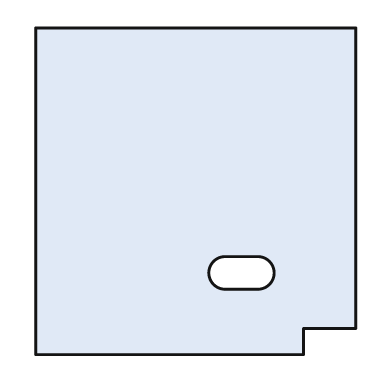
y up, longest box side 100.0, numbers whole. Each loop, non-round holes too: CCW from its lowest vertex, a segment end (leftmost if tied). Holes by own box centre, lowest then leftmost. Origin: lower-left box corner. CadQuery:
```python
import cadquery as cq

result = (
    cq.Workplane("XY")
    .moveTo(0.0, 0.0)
    .lineTo(82.0, 0.0)
    .lineTo(82.0, 8.0)
    .lineTo(98.0, 8.0)
    .lineTo(98.0, 100.0)
    .lineTo(0.0, 100.0)
    .close()
    .moveTo(58.0, 20.0)
    .lineTo(68.0, 20.0)
    .threePointArc((73.0, 25.0), (68.0, 30.0))
    .lineTo(58.0, 30.0)
    .threePointArc((53.0, 25.0), (58.0, 20.0))
    .close()
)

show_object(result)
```